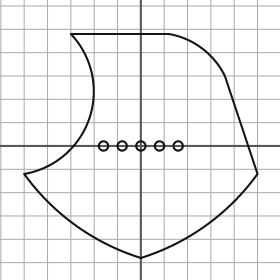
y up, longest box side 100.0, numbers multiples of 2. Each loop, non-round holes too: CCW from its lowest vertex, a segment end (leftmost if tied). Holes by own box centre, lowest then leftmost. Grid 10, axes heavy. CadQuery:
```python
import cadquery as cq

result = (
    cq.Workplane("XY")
    .moveTo(0.0, -48.0)
    .threePointArc((28.0, -34.0), (50.0, -12.0))
    .lineTo(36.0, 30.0)
    .threePointArc((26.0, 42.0), (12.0, 48.0))
    .lineTo(-30.0, 48.0)
    .threePointArc((-22.0, 12.0), (-50.0, -12.0))
    .threePointArc((-28.0, -34.0), (0.0, -48.0))
    .close()
    .moveTo(-16.0, 0.0)
    .circle(2.0)
    .moveTo(-8.0, 0.0)
    .circle(2.0)
    .moveTo(0.0, 0.0)
    .circle(2.0)
    .moveTo(8.0, 0.0)
    .circle(2.0)
    .moveTo(16.0, 0.0)
    .circle(2.0)
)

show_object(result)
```